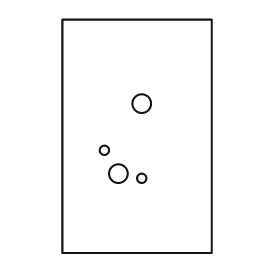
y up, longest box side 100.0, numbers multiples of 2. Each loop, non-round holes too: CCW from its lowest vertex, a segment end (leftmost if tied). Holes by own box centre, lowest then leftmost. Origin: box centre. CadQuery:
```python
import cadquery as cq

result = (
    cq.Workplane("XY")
    .moveTo(-32.0, -50.0)
    .lineTo(32.0, -50.0)
    .lineTo(32.0, 50.0)
    .lineTo(-32.0, 50.0)
    .close()
    .moveTo(2.0, -18.0)
    .circle(2.0)
    .moveTo(-8.0, -16.0)
    .circle(4.0)
    .moveTo(-14.0, -6.0)
    .circle(2.0)
    .moveTo(2.0, 14.0)
    .circle(4.0)
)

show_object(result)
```